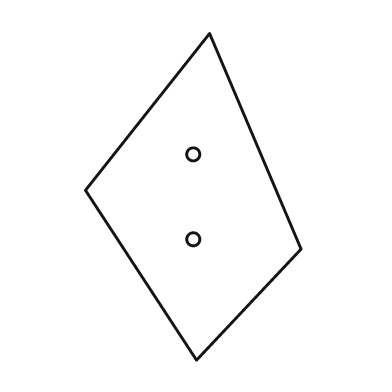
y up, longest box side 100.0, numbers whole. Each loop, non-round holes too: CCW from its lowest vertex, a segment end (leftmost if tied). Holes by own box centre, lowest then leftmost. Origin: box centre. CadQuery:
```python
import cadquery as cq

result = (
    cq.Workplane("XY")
    .moveTo(1.0, -50.0)
    .lineTo(33.0, -16.0)
    .lineTo(5.0, 50.0)
    .lineTo(-33.0, 2.0)
    .close()
    .moveTo(0.0, -13.0)
    .circle(2.0)
    .moveTo(0.0, 13.0)
    .circle(2.0)
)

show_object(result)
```